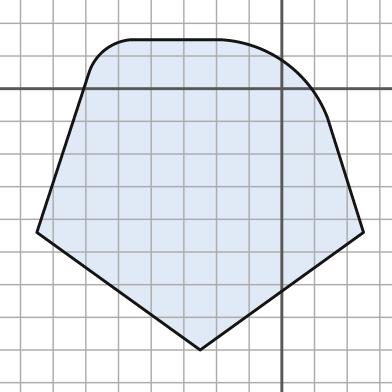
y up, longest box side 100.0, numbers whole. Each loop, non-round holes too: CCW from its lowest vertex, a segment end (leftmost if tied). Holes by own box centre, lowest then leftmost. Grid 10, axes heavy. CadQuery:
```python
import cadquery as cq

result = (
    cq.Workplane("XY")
    .moveTo(-25.0, -80.0)
    .lineTo(25.0, -44.0)
    .lineTo(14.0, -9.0)
    .threePointArc((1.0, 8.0), (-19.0, 15.0))
    .lineTo(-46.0, 15.0)
    .threePointArc((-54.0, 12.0), (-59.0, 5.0))
    .lineTo(-75.0, -44.0)
    .close()
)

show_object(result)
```